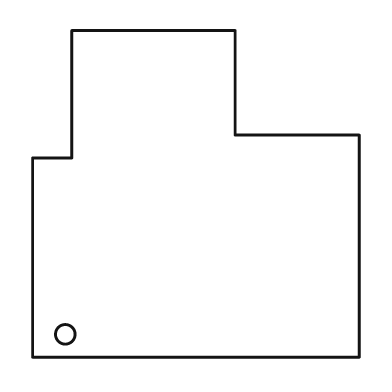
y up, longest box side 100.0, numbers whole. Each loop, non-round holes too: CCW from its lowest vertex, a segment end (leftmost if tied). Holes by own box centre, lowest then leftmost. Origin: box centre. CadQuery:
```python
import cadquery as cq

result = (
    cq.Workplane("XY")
    .moveTo(-50.0, -50.0)
    .lineTo(50.0, -50.0)
    .lineTo(50.0, 18.0)
    .lineTo(12.0, 18.0)
    .lineTo(12.0, 50.0)
    .lineTo(-38.0, 50.0)
    .lineTo(-38.0, 11.0)
    .lineTo(-50.0, 11.0)
    .close()
    .moveTo(-40.0, -43.0)
    .circle(3.0)
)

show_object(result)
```